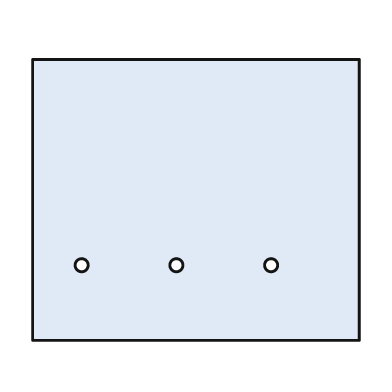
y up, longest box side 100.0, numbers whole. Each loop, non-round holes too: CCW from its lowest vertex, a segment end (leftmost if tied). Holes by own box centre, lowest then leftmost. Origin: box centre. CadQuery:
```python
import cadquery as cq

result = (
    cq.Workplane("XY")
    .moveTo(-50.0, -43.0)
    .lineTo(50.0, -43.0)
    .lineTo(50.0, 43.0)
    .lineTo(-50.0, 43.0)
    .close()
    .moveTo(-35.0, -20.0)
    .circle(2.0)
    .moveTo(-6.0, -20.0)
    .circle(2.0)
    .moveTo(23.0, -20.0)
    .circle(2.0)
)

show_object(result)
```